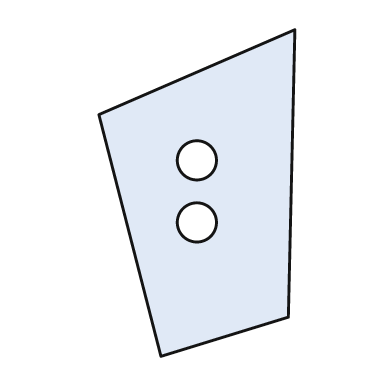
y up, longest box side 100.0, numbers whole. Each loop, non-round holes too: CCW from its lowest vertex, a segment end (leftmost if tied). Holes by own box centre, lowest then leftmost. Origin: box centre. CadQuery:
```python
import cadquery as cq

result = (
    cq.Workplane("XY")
    .moveTo(-11.0, -50.0)
    .lineTo(28.0, -38.0)
    .lineTo(30.0, 50.0)
    .lineTo(-30.0, 24.0)
    .close()
    .moveTo(0.0, -9.0)
    .circle(6.0)
    .moveTo(0.0, 10.0)
    .circle(6.0)
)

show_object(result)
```